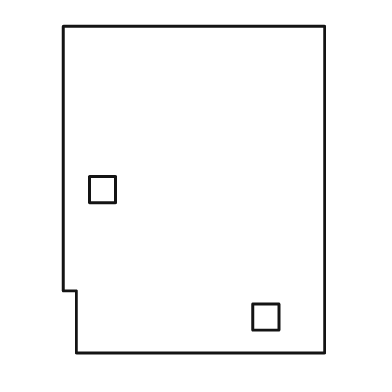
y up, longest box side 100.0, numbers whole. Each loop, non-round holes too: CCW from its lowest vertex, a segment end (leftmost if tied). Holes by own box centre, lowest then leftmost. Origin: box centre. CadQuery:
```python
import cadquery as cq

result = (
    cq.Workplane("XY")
    .moveTo(-36.0, -50.0)
    .lineTo(40.0, -50.0)
    .lineTo(40.0, 50.0)
    .lineTo(-40.0, 50.0)
    .lineTo(-40.0, -31.0)
    .lineTo(-36.0, -31.0)
    .close()
    .moveTo(18.0, -43.0)
    .lineTo(26.0, -43.0)
    .lineTo(26.0, -35.0)
    .lineTo(18.0, -35.0)
    .close()
    .moveTo(-32.0, -4.0)
    .lineTo(-24.0, -4.0)
    .lineTo(-24.0, 4.0)
    .lineTo(-32.0, 4.0)
    .close()
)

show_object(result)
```